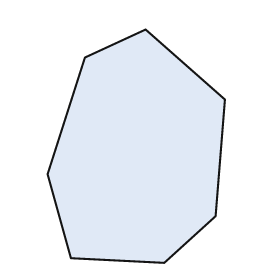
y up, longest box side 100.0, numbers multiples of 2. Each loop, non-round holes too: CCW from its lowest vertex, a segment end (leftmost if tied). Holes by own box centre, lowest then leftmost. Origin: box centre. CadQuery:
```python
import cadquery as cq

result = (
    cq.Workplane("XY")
    .moveTo(12.0, -50.0)
    .lineTo(34.0, -30.0)
    .lineTo(38.0, 20.0)
    .lineTo(4.0, 50.0)
    .lineTo(-22.0, 38.0)
    .lineTo(-38.0, -12.0)
    .lineTo(-28.0, -48.0)
    .close()
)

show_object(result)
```